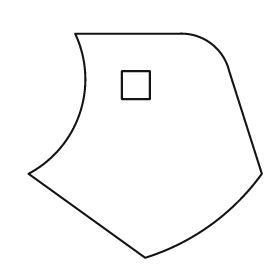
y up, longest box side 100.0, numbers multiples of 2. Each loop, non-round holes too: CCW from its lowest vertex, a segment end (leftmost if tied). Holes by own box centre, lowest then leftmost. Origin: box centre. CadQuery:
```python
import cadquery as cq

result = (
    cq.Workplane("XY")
    .moveTo(0.0, -48.0)
    .threePointArc((28.0, -34.0), (50.0, -12.0))
    .lineTo(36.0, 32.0)
    .threePointArc((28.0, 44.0), (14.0, 48.0))
    .lineTo(-30.0, 48.0)
    .threePointArc((-28.0, 14.0), (-50.0, -12.0))
    .close()
    .moveTo(-10.0, 20.0)
    .lineTo(2.0, 20.0)
    .lineTo(2.0, 32.0)
    .lineTo(-10.0, 32.0)
    .close()
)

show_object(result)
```